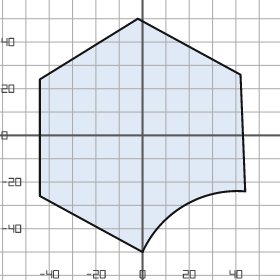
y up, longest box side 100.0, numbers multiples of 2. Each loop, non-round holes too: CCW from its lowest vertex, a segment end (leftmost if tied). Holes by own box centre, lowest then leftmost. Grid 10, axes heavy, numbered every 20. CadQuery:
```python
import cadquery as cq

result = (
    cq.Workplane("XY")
    .moveTo(0.0, -50.0)
    .threePointArc((18.0, -30.0), (44.0, -24.0))
    .lineTo(42.0, 26.0)
    .lineTo(-2.0, 50.0)
    .lineTo(-44.0, 24.0)
    .lineTo(-44.0, -26.0)
    .close()
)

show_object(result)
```